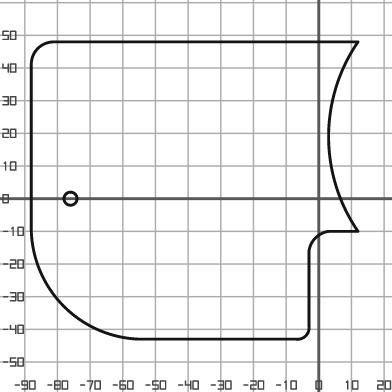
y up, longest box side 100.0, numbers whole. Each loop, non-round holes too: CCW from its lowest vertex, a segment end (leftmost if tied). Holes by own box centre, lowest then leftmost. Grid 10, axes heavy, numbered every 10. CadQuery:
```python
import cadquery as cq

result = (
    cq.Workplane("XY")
    .moveTo(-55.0, -43.0)
    .lineTo(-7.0, -43.0)
    .threePointArc((-4.0, -42.0), (-3.0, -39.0))
    .lineTo(-3.0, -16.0)
    .threePointArc((-1.0, -12.0), (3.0, -10.0))
    .lineTo(12.0, -10.0)
    .threePointArc((3.0, 19.0), (12.0, 48.0))
    .lineTo(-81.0, 48.0)
    .threePointArc((-86.0, 46.0), (-88.0, 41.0))
    .lineTo(-88.0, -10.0)
    .threePointArc((-78.0, -33.0), (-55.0, -43.0))
    .close()
    .moveTo(-76.0, 0.0)
    .circle(2.0)
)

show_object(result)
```